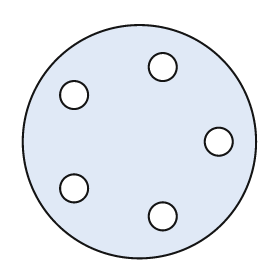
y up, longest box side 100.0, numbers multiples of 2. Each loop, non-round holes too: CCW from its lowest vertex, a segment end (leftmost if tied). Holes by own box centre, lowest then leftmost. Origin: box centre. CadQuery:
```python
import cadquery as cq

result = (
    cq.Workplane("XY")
    .moveTo(0.0, 0.0)
    .circle(50.0)
    .moveTo(10.0, -32.0)
    .circle(6.0)
    .moveTo(-28.0, -20.0)
    .circle(6.0)
    .moveTo(34.0, 0.0)
    .circle(6.0)
    .moveTo(-28.0, 20.0)
    .circle(6.0)
    .moveTo(10.0, 32.0)
    .circle(6.0)
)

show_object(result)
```